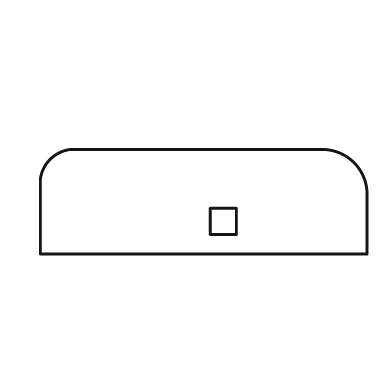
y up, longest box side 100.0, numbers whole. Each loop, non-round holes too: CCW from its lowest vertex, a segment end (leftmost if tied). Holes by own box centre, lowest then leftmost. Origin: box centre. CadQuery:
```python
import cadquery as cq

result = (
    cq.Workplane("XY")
    .moveTo(-50.0, -16.0)
    .lineTo(50.0, -16.0)
    .lineTo(50.0, 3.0)
    .threePointArc((46.0, 12.0), (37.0, 16.0))
    .lineTo(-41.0, 16.0)
    .threePointArc((-47.0, 13.0), (-50.0, 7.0))
    .close()
    .moveTo(2.0, -10.0)
    .lineTo(10.0, -10.0)
    .lineTo(10.0, -2.0)
    .lineTo(2.0, -2.0)
    .close()
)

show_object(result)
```